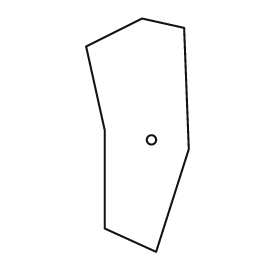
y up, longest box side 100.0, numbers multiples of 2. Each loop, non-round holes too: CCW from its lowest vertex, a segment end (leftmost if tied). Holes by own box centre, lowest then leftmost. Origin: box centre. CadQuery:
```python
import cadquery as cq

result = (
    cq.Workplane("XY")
    .moveTo(8.0, -50.0)
    .lineTo(22.0, -6.0)
    .lineTo(20.0, 46.0)
    .lineTo(2.0, 50.0)
    .lineTo(-22.0, 38.0)
    .lineTo(-14.0, 2.0)
    .lineTo(-14.0, -40.0)
    .close()
    .moveTo(6.0, -2.0)
    .circle(2.0)
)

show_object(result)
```